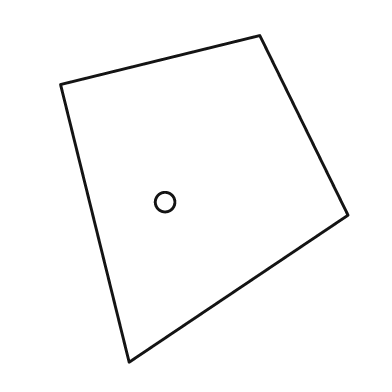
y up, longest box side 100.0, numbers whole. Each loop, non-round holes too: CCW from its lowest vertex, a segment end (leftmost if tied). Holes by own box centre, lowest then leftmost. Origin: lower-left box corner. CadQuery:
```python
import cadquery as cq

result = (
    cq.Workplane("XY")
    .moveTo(21.0, 0.0)
    .lineTo(88.0, 45.0)
    .lineTo(61.0, 100.0)
    .lineTo(0.0, 85.0)
    .close()
    .moveTo(32.0, 49.0)
    .circle(3.0)
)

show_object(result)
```